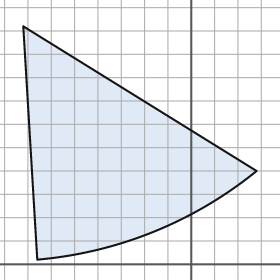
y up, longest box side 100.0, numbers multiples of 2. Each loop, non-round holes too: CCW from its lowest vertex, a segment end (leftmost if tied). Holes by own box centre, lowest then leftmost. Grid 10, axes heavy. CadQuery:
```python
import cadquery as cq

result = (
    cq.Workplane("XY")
    .moveTo(-66.0, 2.0)
    .threePointArc((-16.0, 14.0), (28.0, 40.0))
    .lineTo(-72.0, 102.0)
    .close()
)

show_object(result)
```